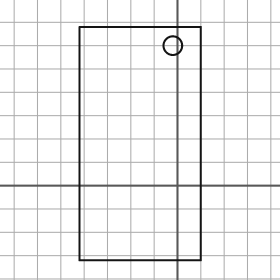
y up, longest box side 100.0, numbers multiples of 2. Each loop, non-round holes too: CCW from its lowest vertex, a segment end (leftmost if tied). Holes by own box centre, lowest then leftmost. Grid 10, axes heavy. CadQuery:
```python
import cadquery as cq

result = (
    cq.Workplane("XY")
    .moveTo(-42.0, -32.0)
    .lineTo(10.0, -32.0)
    .lineTo(10.0, 68.0)
    .lineTo(-42.0, 68.0)
    .close()
    .moveTo(-2.0, 60.0)
    .circle(4.0)
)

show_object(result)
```